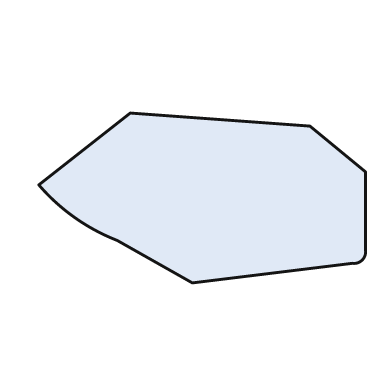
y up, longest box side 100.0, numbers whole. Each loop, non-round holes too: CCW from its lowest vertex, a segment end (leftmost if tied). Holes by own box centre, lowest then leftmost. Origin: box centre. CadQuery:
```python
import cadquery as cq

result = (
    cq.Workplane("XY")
    .moveTo(-3.0, -26.0)
    .lineTo(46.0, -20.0)
    .threePointArc((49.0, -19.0), (50.0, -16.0))
    .lineTo(50.0, 8.0)
    .lineTo(33.0, 22.0)
    .lineTo(-22.0, 26.0)
    .lineTo(-50.0, 4.0)
    .threePointArc((-39.0, -6.0), (-26.0, -13.0))
    .close()
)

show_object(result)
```